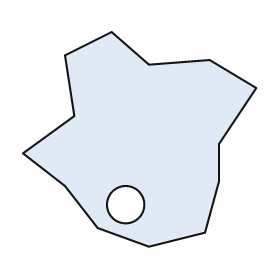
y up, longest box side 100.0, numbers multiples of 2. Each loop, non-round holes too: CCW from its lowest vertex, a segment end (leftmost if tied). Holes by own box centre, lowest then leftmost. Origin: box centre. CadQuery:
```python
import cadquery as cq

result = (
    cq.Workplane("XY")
    .moveTo(4.0, -46.0)
    .lineTo(28.0, -40.0)
    .lineTo(34.0, -18.0)
    .lineTo(34.0, -2.0)
    .lineTo(50.0, 22.0)
    .lineTo(30.0, 34.0)
    .lineTo(4.0, 32.0)
    .lineTo(-12.0, 46.0)
    .lineTo(-32.0, 36.0)
    .lineTo(-28.0, 10.0)
    .lineTo(-50.0, -6.0)
    .lineTo(-32.0, -20.0)
    .lineTo(-18.0, -38.0)
    .close()
    .moveTo(-6.0, -28.0)
    .circle(8.0)
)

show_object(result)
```